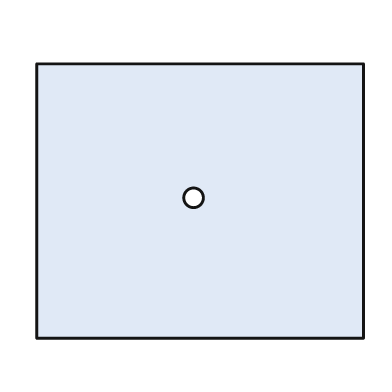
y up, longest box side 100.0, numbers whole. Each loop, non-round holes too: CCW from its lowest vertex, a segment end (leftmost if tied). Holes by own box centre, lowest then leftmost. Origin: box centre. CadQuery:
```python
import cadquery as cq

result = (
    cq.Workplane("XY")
    .moveTo(-50.0, -42.0)
    .lineTo(50.0, -42.0)
    .lineTo(50.0, 42.0)
    .lineTo(-50.0, 42.0)
    .close()
    .moveTo(-2.0, 1.0)
    .circle(3.0)
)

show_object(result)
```